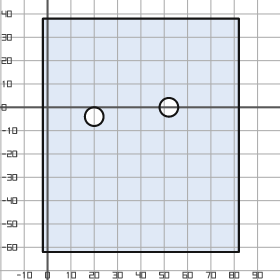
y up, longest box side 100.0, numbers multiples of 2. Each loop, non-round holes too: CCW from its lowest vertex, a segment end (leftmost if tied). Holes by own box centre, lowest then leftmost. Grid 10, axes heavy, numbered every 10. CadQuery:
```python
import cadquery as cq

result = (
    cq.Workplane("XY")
    .moveTo(-2.0, -62.0)
    .lineTo(82.0, -62.0)
    .lineTo(82.0, 38.0)
    .lineTo(-2.0, 38.0)
    .close()
    .moveTo(20.0, -4.0)
    .circle(4.0)
    .moveTo(52.0, 0.0)
    .circle(4.0)
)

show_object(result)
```